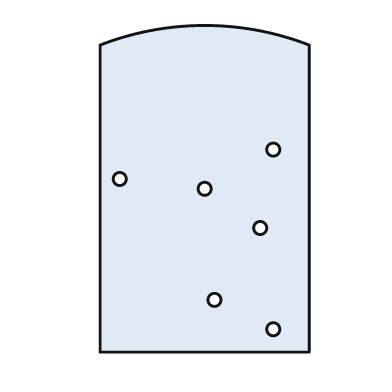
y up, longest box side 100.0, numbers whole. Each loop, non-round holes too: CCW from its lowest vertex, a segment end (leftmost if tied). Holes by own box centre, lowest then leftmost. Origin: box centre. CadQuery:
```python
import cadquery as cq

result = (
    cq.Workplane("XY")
    .moveTo(-32.0, -50.0)
    .lineTo(32.0, -50.0)
    .lineTo(32.0, 44.0)
    .threePointArc((0.0, 50.0), (-32.0, 44.0))
    .close()
    .moveTo(21.0, -43.0)
    .circle(2.0)
    .moveTo(3.0, -34.0)
    .circle(2.0)
    .moveTo(17.0, -12.0)
    .circle(2.0)
    .moveTo(0.0, 0.0)
    .circle(2.0)
    .moveTo(-26.0, 3.0)
    .circle(2.0)
    .moveTo(21.0, 12.0)
    .circle(2.0)
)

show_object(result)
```